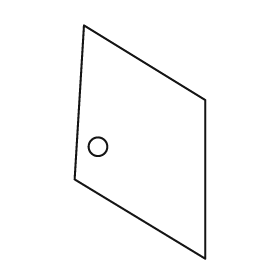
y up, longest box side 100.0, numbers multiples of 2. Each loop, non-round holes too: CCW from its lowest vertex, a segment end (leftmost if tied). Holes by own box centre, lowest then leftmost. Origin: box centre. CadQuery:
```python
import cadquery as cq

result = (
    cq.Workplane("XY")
    .moveTo(28.0, -50.0)
    .lineTo(28.0, 18.0)
    .lineTo(-24.0, 50.0)
    .lineTo(-28.0, -16.0)
    .close()
    .moveTo(-18.0, -2.0)
    .circle(4.0)
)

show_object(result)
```